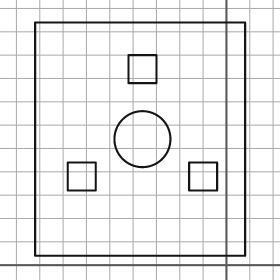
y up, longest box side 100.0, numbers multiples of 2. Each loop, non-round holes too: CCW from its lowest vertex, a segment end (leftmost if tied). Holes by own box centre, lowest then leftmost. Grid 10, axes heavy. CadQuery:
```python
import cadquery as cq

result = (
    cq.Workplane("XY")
    .moveTo(-82.0, 4.0)
    .lineTo(8.0, 4.0)
    .lineTo(8.0, 104.0)
    .lineTo(-82.0, 104.0)
    .close()
    .moveTo(-68.0, 32.0)
    .lineTo(-56.0, 32.0)
    .lineTo(-56.0, 44.0)
    .lineTo(-68.0, 44.0)
    .close()
    .moveTo(-16.0, 32.0)
    .lineTo(-4.0, 32.0)
    .lineTo(-4.0, 44.0)
    .lineTo(-16.0, 44.0)
    .close()
    .moveTo(-36.0, 54.0)
    .circle(12.0)
    .moveTo(-42.0, 78.0)
    .lineTo(-30.0, 78.0)
    .lineTo(-30.0, 90.0)
    .lineTo(-42.0, 90.0)
    .close()
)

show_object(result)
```